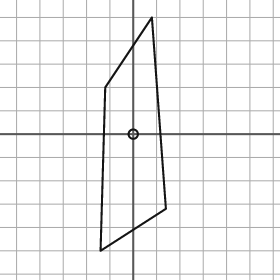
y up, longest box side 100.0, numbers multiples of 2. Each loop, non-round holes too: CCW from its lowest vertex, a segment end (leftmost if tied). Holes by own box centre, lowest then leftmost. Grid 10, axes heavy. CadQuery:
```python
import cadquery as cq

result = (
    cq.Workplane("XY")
    .moveTo(-14.0, -50.0)
    .lineTo(14.0, -32.0)
    .lineTo(8.0, 50.0)
    .lineTo(-12.0, 20.0)
    .close()
    .moveTo(0.0, 0.0)
    .circle(2.0)
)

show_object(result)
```